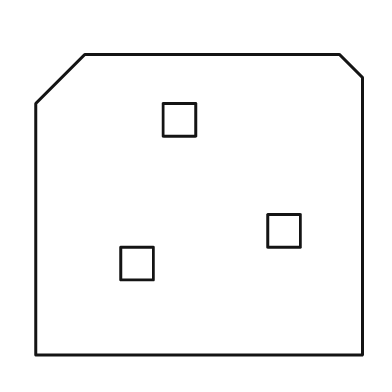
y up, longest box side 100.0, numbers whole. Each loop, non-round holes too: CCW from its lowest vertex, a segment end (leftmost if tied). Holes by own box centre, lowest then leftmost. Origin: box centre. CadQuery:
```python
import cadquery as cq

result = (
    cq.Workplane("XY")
    .moveTo(-50.0, -46.0)
    .lineTo(50.0, -46.0)
    .lineTo(50.0, 39.0)
    .lineTo(43.0, 46.0)
    .lineTo(-35.0, 46.0)
    .lineTo(-50.0, 31.0)
    .close()
    .moveTo(-24.0, -23.0)
    .lineTo(-14.0, -23.0)
    .lineTo(-14.0, -13.0)
    .lineTo(-24.0, -13.0)
    .close()
    .moveTo(21.0, -13.0)
    .lineTo(31.0, -13.0)
    .lineTo(31.0, -3.0)
    .lineTo(21.0, -3.0)
    .close()
    .moveTo(-11.0, 21.0)
    .lineTo(-1.0, 21.0)
    .lineTo(-1.0, 31.0)
    .lineTo(-11.0, 31.0)
    .close()
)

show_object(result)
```